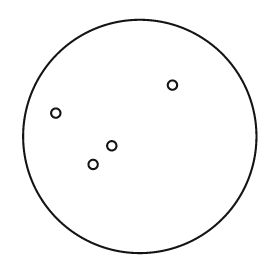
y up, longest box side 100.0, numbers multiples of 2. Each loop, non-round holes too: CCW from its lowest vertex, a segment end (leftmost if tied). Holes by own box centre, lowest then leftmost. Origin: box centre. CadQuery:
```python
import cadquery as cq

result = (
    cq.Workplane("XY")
    .moveTo(0.0, 0.0)
    .circle(50.0)
    .moveTo(-20.0, -12.0)
    .circle(2.0)
    .moveTo(-12.0, -4.0)
    .circle(2.0)
    .moveTo(-36.0, 10.0)
    .circle(2.0)
    .moveTo(14.0, 22.0)
    .circle(2.0)
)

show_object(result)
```